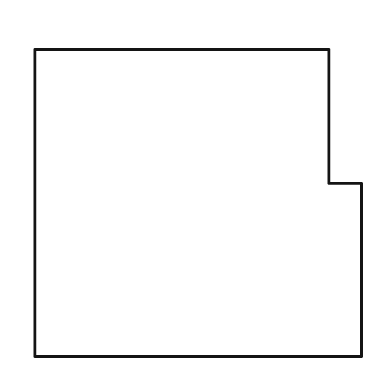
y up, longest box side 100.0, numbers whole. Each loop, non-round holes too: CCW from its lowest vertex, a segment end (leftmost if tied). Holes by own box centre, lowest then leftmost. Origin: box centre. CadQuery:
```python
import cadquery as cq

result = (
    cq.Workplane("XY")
    .moveTo(-50.0, -47.0)
    .lineTo(50.0, -47.0)
    .lineTo(50.0, 6.0)
    .lineTo(40.0, 6.0)
    .lineTo(40.0, 47.0)
    .lineTo(-50.0, 47.0)
    .close()
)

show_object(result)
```